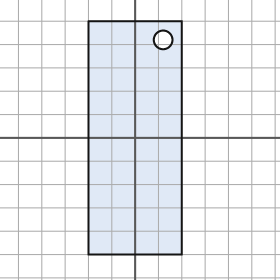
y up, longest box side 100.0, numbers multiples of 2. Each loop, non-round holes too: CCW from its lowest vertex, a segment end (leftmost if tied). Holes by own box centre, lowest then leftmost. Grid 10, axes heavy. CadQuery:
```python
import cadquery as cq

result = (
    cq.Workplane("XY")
    .moveTo(-20.0, -50.0)
    .lineTo(20.0, -50.0)
    .lineTo(20.0, 50.0)
    .lineTo(-20.0, 50.0)
    .close()
    .moveTo(12.0, 42.0)
    .circle(4.0)
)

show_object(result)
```